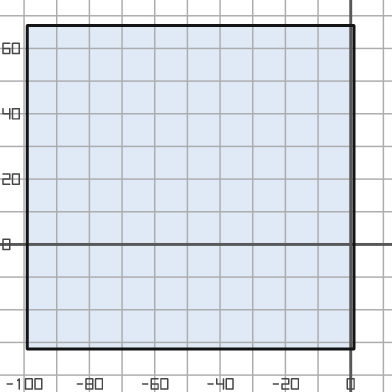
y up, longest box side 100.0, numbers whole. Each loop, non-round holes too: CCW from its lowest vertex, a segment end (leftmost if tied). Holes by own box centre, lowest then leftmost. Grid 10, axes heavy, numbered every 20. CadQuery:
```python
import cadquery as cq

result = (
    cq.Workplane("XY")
    .moveTo(-99.0, -32.0)
    .lineTo(1.0, -32.0)
    .lineTo(1.0, 67.0)
    .lineTo(-99.0, 67.0)
    .close()
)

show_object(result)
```